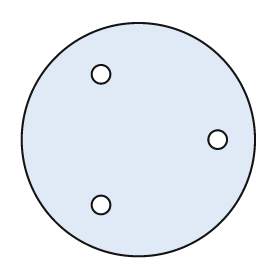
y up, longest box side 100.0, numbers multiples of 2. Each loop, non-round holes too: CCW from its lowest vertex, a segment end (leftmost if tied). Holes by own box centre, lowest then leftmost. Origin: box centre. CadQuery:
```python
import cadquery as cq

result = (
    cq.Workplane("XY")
    .moveTo(0.0, 0.0)
    .circle(50.0)
    .moveTo(-16.0, -28.0)
    .circle(4.0)
    .moveTo(34.0, 0.0)
    .circle(4.0)
    .moveTo(-16.0, 28.0)
    .circle(4.0)
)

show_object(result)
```